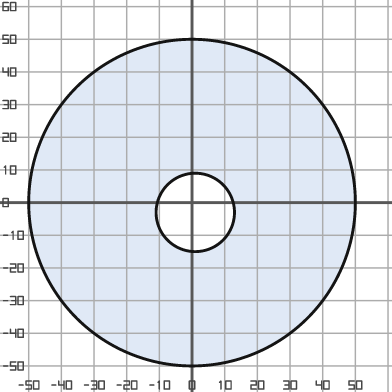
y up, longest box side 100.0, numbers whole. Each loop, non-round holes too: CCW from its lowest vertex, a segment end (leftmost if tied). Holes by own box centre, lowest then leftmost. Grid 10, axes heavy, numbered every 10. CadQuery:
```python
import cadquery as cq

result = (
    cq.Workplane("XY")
    .moveTo(0.0, 0.0)
    .circle(50.0)
    .moveTo(1.0, -3.0)
    .circle(12.0)
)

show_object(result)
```